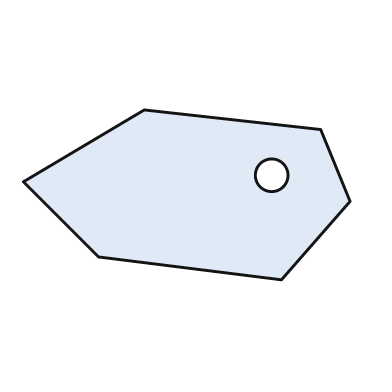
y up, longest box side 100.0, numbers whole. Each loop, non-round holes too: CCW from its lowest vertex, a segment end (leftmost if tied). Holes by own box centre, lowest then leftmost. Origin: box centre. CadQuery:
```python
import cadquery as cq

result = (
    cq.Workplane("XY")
    .moveTo(29.0, -26.0)
    .lineTo(50.0, -2.0)
    .lineTo(41.0, 20.0)
    .lineTo(-13.0, 26.0)
    .lineTo(-50.0, 4.0)
    .lineTo(-27.0, -19.0)
    .close()
    .moveTo(26.0, 6.0)
    .circle(5.0)
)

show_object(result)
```